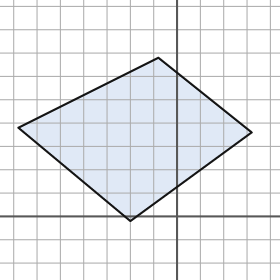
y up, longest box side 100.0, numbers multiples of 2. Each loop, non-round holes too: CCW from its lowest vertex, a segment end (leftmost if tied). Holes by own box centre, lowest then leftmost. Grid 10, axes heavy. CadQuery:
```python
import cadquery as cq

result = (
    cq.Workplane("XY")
    .moveTo(-20.0, -2.0)
    .lineTo(32.0, 36.0)
    .lineTo(-8.0, 68.0)
    .lineTo(-68.0, 38.0)
    .close()
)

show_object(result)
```